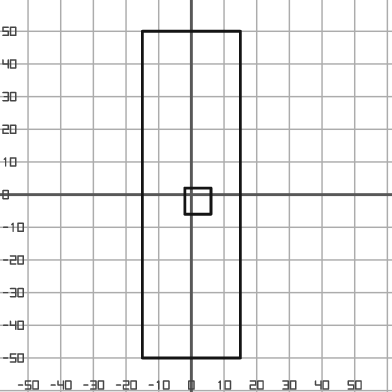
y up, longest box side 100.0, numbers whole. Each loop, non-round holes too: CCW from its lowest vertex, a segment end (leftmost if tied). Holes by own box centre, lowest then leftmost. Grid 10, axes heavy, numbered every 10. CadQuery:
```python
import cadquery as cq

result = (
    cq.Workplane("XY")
    .moveTo(-15.0, -50.0)
    .lineTo(15.0, -50.0)
    .lineTo(15.0, 50.0)
    .lineTo(-15.0, 50.0)
    .close()
    .moveTo(-2.0, -6.0)
    .lineTo(6.0, -6.0)
    .lineTo(6.0, 2.0)
    .lineTo(-2.0, 2.0)
    .close()
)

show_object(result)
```